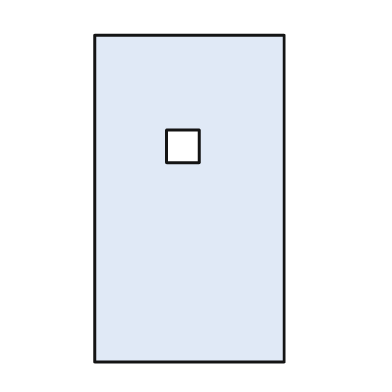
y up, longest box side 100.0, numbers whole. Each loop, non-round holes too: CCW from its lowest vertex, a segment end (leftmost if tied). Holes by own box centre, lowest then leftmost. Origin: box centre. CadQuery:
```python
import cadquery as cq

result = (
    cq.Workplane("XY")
    .moveTo(-29.0, -50.0)
    .lineTo(29.0, -50.0)
    .lineTo(29.0, 50.0)
    .lineTo(-29.0, 50.0)
    .close()
    .moveTo(-7.0, 11.0)
    .lineTo(3.0, 11.0)
    .lineTo(3.0, 21.0)
    .lineTo(-7.0, 21.0)
    .close()
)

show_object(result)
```